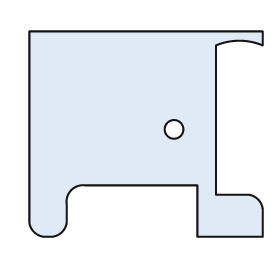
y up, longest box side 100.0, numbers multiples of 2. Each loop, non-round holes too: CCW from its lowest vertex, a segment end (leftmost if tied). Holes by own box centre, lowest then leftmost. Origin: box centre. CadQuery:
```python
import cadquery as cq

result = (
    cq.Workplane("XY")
    .moveTo(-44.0, -44.0)
    .lineTo(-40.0, -44.0)
    .threePointArc((-36.0, -42.0), (-34.0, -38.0))
    .lineTo(-34.0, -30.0)
    .threePointArc((-32.0, -24.0), (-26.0, -22.0))
    .lineTo(22.0, -22.0)
    .lineTo(22.0, -44.0)
    .lineTo(50.0, -44.0)
    .lineTo(50.0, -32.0)
    .threePointArc((48.0, -28.0), (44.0, -26.0))
    .lineTo(30.0, -26.0)
    .lineTo(30.0, 38.0)
    .threePointArc((40.0, 40.0), (50.0, 38.0))
    .lineTo(50.0, 44.0)
    .lineTo(-50.0, 44.0)
    .lineTo(-50.0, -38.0)
    .threePointArc((-48.0, -42.0), (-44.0, -44.0))
    .close()
    .moveTo(12.0, 2.0)
    .circle(4.0)
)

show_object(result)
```